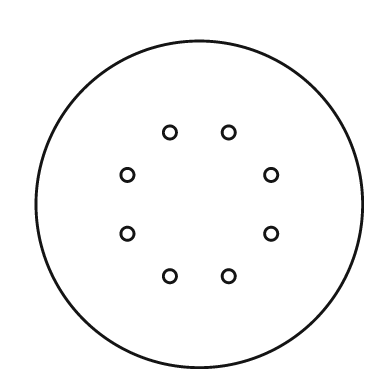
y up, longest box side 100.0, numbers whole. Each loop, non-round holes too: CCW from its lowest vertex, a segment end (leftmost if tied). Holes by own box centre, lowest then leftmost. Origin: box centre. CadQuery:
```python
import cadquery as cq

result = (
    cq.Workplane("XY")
    .moveTo(0.0, 0.0)
    .circle(50.0)
    .moveTo(-9.0, -22.0)
    .circle(2.0)
    .moveTo(9.0, -22.0)
    .circle(2.0)
    .moveTo(-22.0, -9.0)
    .circle(2.0)
    .moveTo(22.0, -9.0)
    .circle(2.0)
    .moveTo(-22.0, 9.0)
    .circle(2.0)
    .moveTo(22.0, 9.0)
    .circle(2.0)
    .moveTo(-9.0, 22.0)
    .circle(2.0)
    .moveTo(9.0, 22.0)
    .circle(2.0)
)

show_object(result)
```